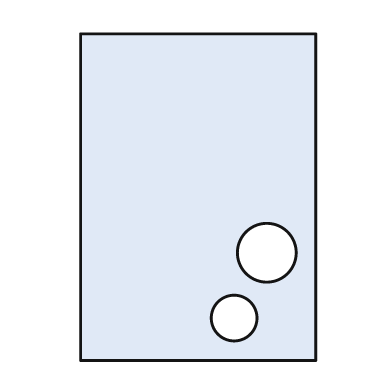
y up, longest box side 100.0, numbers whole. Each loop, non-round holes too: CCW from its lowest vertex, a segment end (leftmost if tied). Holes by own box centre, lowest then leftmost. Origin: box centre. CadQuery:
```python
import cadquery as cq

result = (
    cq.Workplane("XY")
    .moveTo(-36.0, -50.0)
    .lineTo(36.0, -50.0)
    .lineTo(36.0, 50.0)
    .lineTo(-36.0, 50.0)
    .close()
    .moveTo(11.0, -37.0)
    .circle(7.0)
    .moveTo(21.0, -17.0)
    .circle(9.0)
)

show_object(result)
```